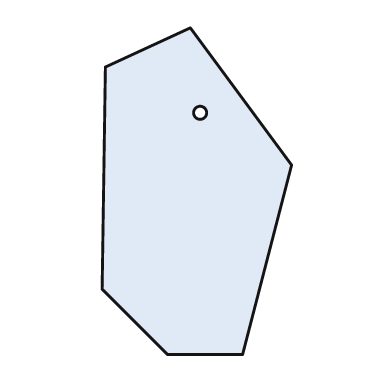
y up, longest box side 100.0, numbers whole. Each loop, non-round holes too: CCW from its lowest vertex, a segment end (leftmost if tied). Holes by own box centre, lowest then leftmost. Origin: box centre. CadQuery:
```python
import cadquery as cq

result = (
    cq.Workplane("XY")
    .moveTo(-9.0, -50.0)
    .lineTo(14.0, -50.0)
    .lineTo(29.0, 8.0)
    .lineTo(-2.0, 50.0)
    .lineTo(-28.0, 38.0)
    .lineTo(-29.0, -30.0)
    .close()
    .moveTo(1.0, 24.0)
    .circle(2.0)
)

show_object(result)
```